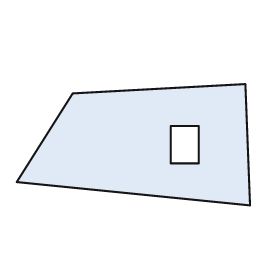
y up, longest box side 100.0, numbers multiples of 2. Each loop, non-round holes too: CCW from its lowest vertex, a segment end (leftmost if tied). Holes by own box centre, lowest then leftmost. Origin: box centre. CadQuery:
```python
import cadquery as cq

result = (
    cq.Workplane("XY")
    .moveTo(50.0, -26.0)
    .lineTo(48.0, 26.0)
    .lineTo(-26.0, 22.0)
    .lineTo(-50.0, -16.0)
    .close()
    .moveTo(16.0, -8.0)
    .lineTo(28.0, -8.0)
    .lineTo(28.0, 8.0)
    .lineTo(16.0, 8.0)
    .close()
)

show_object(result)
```